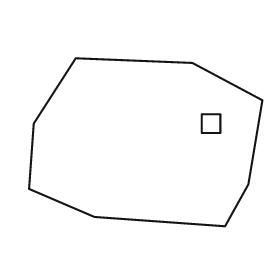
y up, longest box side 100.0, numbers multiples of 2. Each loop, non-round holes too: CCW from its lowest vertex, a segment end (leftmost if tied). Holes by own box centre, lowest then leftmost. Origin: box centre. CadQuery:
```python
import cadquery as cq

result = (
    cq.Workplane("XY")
    .moveTo(34.0, -36.0)
    .lineTo(44.0, -18.0)
    .lineTo(50.0, 18.0)
    .lineTo(20.0, 34.0)
    .lineTo(-30.0, 36.0)
    .lineTo(-48.0, 8.0)
    .lineTo(-50.0, -20.0)
    .lineTo(-22.0, -32.0)
    .close()
    .moveTo(24.0, 4.0)
    .lineTo(32.0, 4.0)
    .lineTo(32.0, 12.0)
    .lineTo(24.0, 12.0)
    .close()
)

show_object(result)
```